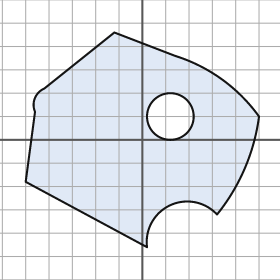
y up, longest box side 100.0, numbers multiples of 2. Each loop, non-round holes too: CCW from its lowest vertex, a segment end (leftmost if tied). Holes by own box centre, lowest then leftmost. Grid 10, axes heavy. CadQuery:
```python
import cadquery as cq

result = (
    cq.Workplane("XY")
    .moveTo(2.0, -46.0)
    .threePointArc((12.0, -28.0), (32.0, -32.0))
    .threePointArc((44.0, -12.0), (50.0, 10.0))
    .threePointArc((34.0, 26.0), (14.0, 36.0))
    .lineTo(-12.0, 46.0)
    .lineTo(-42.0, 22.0)
    .threePointArc((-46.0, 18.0), (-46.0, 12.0))
    .lineTo(-50.0, -18.0)
    .close()
    .moveTo(12.0, 10.0)
    .circle(10.0)
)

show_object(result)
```